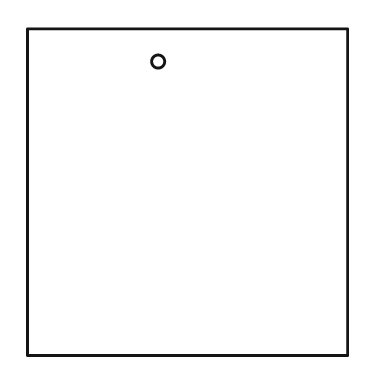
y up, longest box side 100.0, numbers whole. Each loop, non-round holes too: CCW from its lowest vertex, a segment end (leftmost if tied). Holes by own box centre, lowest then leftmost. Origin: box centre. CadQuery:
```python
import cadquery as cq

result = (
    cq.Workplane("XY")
    .moveTo(-49.0, -50.0)
    .lineTo(49.0, -50.0)
    .lineTo(49.0, 50.0)
    .lineTo(-49.0, 50.0)
    .close()
    .moveTo(-9.0, 40.0)
    .circle(2.0)
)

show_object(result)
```